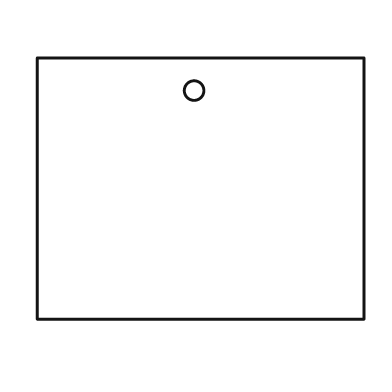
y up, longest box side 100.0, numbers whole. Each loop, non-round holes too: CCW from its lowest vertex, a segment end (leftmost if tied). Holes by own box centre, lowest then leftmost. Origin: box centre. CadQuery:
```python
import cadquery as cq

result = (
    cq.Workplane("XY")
    .moveTo(-50.0, -40.0)
    .lineTo(50.0, -40.0)
    .lineTo(50.0, 40.0)
    .lineTo(-50.0, 40.0)
    .close()
    .moveTo(-2.0, 30.0)
    .circle(3.0)
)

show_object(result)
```